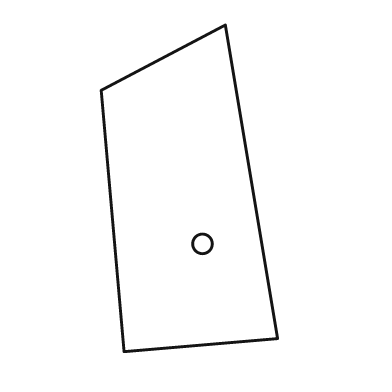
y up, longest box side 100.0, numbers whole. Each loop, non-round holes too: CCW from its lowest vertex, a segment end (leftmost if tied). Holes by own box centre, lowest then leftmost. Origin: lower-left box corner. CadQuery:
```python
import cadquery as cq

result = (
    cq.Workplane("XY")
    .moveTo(7.0, 0.0)
    .lineTo(54.0, 4.0)
    .lineTo(38.0, 100.0)
    .lineTo(0.0, 80.0)
    .close()
    .moveTo(31.0, 33.0)
    .circle(3.0)
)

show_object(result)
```